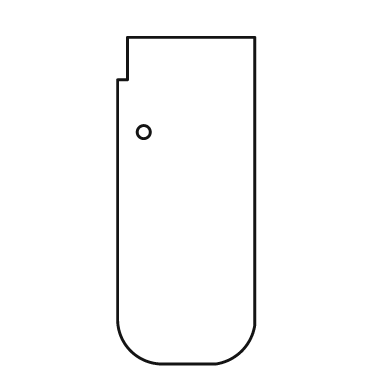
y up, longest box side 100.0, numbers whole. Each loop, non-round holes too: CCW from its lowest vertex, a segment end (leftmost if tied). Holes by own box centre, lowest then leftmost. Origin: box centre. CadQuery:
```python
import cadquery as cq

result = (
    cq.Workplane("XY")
    .moveTo(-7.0, -50.0)
    .lineTo(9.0, -50.0)
    .threePointArc((17.0, -46.0), (21.0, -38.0))
    .lineTo(21.0, 50.0)
    .lineTo(-18.0, 50.0)
    .lineTo(-18.0, 37.0)
    .lineTo(-21.0, 37.0)
    .lineTo(-21.0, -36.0)
    .threePointArc((-17.0, -46.0), (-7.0, -50.0))
    .close()
    .moveTo(-13.0, 21.0)
    .circle(2.0)
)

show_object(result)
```